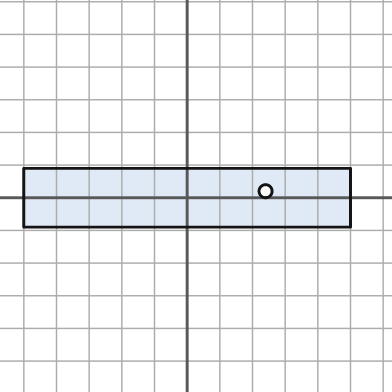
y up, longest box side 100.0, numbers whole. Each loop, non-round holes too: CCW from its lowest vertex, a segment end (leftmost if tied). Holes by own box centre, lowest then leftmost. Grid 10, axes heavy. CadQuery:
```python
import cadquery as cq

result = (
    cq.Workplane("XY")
    .moveTo(-50.0, -9.0)
    .lineTo(50.0, -9.0)
    .lineTo(50.0, 9.0)
    .lineTo(-50.0, 9.0)
    .close()
    .moveTo(24.0, 2.0)
    .circle(2.0)
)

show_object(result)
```